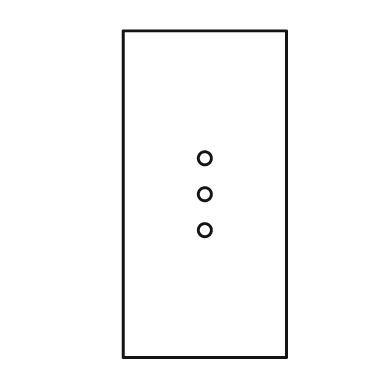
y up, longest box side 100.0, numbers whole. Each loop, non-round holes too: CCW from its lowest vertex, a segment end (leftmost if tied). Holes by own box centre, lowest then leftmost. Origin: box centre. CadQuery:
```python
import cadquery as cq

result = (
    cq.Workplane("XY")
    .moveTo(-25.0, -50.0)
    .lineTo(25.0, -50.0)
    .lineTo(25.0, 50.0)
    .lineTo(-25.0, 50.0)
    .close()
    .moveTo(0.0, -11.0)
    .circle(2.0)
    .moveTo(0.0, 0.0)
    .circle(2.0)
    .moveTo(0.0, 11.0)
    .circle(2.0)
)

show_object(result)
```